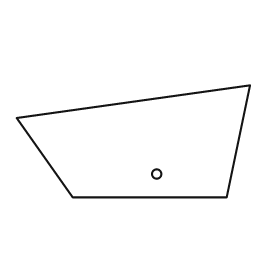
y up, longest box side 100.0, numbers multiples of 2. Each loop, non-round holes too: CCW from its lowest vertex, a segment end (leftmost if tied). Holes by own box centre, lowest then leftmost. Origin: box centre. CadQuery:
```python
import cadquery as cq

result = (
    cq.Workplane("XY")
    .moveTo(-26.0, -24.0)
    .lineTo(40.0, -24.0)
    .lineTo(50.0, 24.0)
    .lineTo(-50.0, 10.0)
    .close()
    .moveTo(10.0, -14.0)
    .circle(2.0)
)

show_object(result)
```